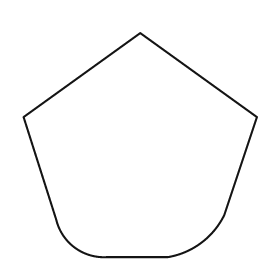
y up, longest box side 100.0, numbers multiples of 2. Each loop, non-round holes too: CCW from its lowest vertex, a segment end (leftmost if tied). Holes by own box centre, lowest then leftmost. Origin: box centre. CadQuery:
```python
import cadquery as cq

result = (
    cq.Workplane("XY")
    .moveTo(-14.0, -48.0)
    .lineTo(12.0, -48.0)
    .threePointArc((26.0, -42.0), (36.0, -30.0))
    .lineTo(50.0, 12.0)
    .lineTo(0.0, 48.0)
    .lineTo(-50.0, 12.0)
    .lineTo(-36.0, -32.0)
    .threePointArc((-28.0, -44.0), (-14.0, -48.0))
    .close()
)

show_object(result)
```